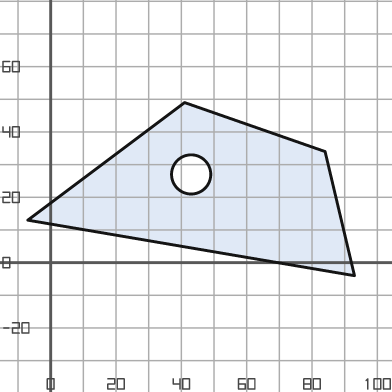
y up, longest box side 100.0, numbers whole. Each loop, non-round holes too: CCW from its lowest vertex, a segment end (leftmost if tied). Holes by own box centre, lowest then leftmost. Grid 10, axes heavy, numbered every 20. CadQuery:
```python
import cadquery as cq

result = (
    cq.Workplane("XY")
    .moveTo(93.0, -4.0)
    .lineTo(84.0, 34.0)
    .lineTo(41.0, 49.0)
    .lineTo(-7.0, 13.0)
    .close()
    .moveTo(43.0, 27.0)
    .circle(6.0)
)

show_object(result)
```